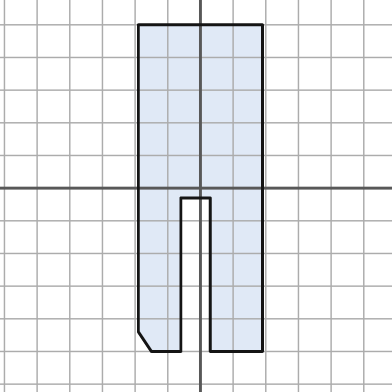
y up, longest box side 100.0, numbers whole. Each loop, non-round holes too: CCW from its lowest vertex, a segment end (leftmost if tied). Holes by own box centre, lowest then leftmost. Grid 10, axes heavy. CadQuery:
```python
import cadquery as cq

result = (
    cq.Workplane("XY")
    .moveTo(-15.0, -50.0)
    .lineTo(-6.0, -50.0)
    .lineTo(-6.0, -3.0)
    .lineTo(3.0, -3.0)
    .lineTo(3.0, -50.0)
    .lineTo(19.0, -50.0)
    .lineTo(19.0, 50.0)
    .lineTo(-19.0, 50.0)
    .lineTo(-19.0, -44.0)
    .close()
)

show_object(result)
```